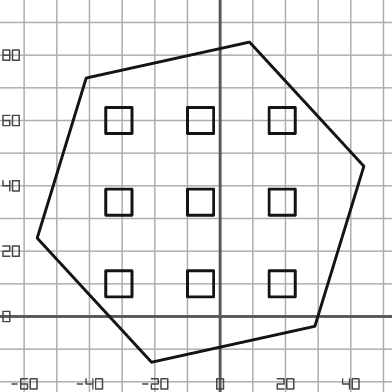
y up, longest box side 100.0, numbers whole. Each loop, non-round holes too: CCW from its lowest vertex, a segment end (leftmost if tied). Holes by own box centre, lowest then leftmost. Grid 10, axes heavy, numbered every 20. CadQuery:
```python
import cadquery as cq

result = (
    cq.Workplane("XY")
    .moveTo(-21.0, -14.0)
    .lineTo(29.0, -3.0)
    .lineTo(44.0, 46.0)
    .lineTo(9.0, 84.0)
    .lineTo(-41.0, 73.0)
    .lineTo(-56.0, 24.0)
    .close()
    .moveTo(-35.0, 6.0)
    .lineTo(-27.0, 6.0)
    .lineTo(-27.0, 14.0)
    .lineTo(-35.0, 14.0)
    .close()
    .moveTo(-10.0, 6.0)
    .lineTo(-2.0, 6.0)
    .lineTo(-2.0, 14.0)
    .lineTo(-10.0, 14.0)
    .close()
    .moveTo(15.0, 6.0)
    .lineTo(23.0, 6.0)
    .lineTo(23.0, 14.0)
    .lineTo(15.0, 14.0)
    .close()
    .moveTo(-35.0, 31.0)
    .lineTo(-27.0, 31.0)
    .lineTo(-27.0, 39.0)
    .lineTo(-35.0, 39.0)
    .close()
    .moveTo(-10.0, 31.0)
    .lineTo(-2.0, 31.0)
    .lineTo(-2.0, 39.0)
    .lineTo(-10.0, 39.0)
    .close()
    .moveTo(15.0, 31.0)
    .lineTo(23.0, 31.0)
    .lineTo(23.0, 39.0)
    .lineTo(15.0, 39.0)
    .close()
    .moveTo(-35.0, 56.0)
    .lineTo(-27.0, 56.0)
    .lineTo(-27.0, 64.0)
    .lineTo(-35.0, 64.0)
    .close()
    .moveTo(-10.0, 56.0)
    .lineTo(-2.0, 56.0)
    .lineTo(-2.0, 64.0)
    .lineTo(-10.0, 64.0)
    .close()
    .moveTo(15.0, 56.0)
    .lineTo(23.0, 56.0)
    .lineTo(23.0, 64.0)
    .lineTo(15.0, 64.0)
    .close()
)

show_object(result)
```